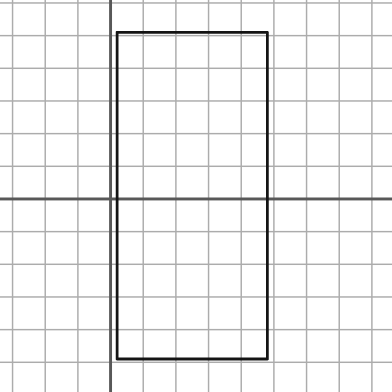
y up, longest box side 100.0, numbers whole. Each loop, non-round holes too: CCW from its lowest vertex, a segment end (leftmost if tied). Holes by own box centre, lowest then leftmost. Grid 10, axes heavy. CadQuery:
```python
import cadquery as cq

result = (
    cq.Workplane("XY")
    .moveTo(2.0, -49.0)
    .lineTo(48.0, -49.0)
    .lineTo(48.0, 51.0)
    .lineTo(2.0, 51.0)
    .close()
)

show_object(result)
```